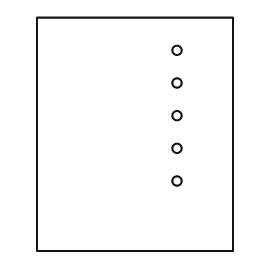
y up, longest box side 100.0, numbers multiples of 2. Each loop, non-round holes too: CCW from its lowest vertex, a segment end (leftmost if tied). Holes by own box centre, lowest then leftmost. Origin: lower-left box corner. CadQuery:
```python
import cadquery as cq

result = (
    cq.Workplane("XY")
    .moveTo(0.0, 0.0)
    .lineTo(84.0, 0.0)
    .lineTo(84.0, 100.0)
    .lineTo(0.0, 100.0)
    .close()
    .moveTo(60.0, 30.0)
    .circle(2.0)
    .moveTo(60.0, 44.0)
    .circle(2.0)
    .moveTo(60.0, 58.0)
    .circle(2.0)
    .moveTo(60.0, 72.0)
    .circle(2.0)
    .moveTo(60.0, 86.0)
    .circle(2.0)
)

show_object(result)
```